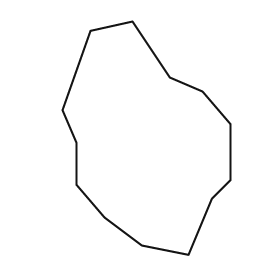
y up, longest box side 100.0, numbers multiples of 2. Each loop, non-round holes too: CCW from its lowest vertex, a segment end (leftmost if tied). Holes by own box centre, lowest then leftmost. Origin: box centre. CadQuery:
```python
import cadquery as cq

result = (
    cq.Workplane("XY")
    .moveTo(18.0, -50.0)
    .lineTo(28.0, -26.0)
    .lineTo(36.0, -18.0)
    .lineTo(36.0, 6.0)
    .lineTo(24.0, 20.0)
    .lineTo(10.0, 26.0)
    .lineTo(-6.0, 50.0)
    .lineTo(-24.0, 46.0)
    .lineTo(-36.0, 12.0)
    .lineTo(-30.0, -2.0)
    .lineTo(-30.0, -20.0)
    .lineTo(-18.0, -34.0)
    .lineTo(-2.0, -46.0)
    .close()
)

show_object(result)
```